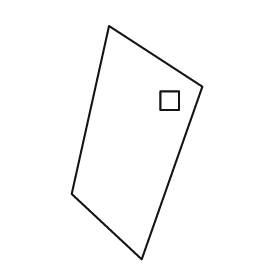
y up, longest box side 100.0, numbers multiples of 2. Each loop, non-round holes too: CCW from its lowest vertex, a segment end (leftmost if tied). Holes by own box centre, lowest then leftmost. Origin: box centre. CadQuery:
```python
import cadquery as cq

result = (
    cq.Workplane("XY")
    .moveTo(2.0, -50.0)
    .lineTo(28.0, 24.0)
    .lineTo(-12.0, 50.0)
    .lineTo(-28.0, -22.0)
    .close()
    .moveTo(10.0, 14.0)
    .lineTo(18.0, 14.0)
    .lineTo(18.0, 22.0)
    .lineTo(10.0, 22.0)
    .close()
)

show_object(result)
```